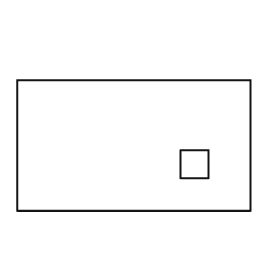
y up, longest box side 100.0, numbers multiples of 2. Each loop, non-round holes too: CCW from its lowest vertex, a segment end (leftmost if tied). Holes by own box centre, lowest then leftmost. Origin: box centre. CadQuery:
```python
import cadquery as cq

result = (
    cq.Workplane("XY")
    .moveTo(-50.0, -28.0)
    .lineTo(50.0, -28.0)
    .lineTo(50.0, 28.0)
    .lineTo(-50.0, 28.0)
    .close()
    .moveTo(20.0, -14.0)
    .lineTo(32.0, -14.0)
    .lineTo(32.0, -2.0)
    .lineTo(20.0, -2.0)
    .close()
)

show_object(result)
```